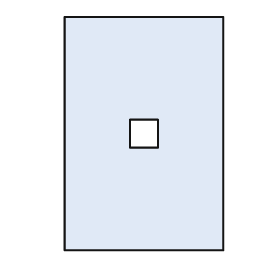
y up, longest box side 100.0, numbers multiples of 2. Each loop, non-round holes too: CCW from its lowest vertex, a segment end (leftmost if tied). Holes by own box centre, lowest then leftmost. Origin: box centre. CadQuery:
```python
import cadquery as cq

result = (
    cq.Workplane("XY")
    .moveTo(-34.0, -50.0)
    .lineTo(34.0, -50.0)
    .lineTo(34.0, 50.0)
    .lineTo(-34.0, 50.0)
    .close()
    .moveTo(-6.0, -6.0)
    .lineTo(6.0, -6.0)
    .lineTo(6.0, 6.0)
    .lineTo(-6.0, 6.0)
    .close()
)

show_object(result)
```